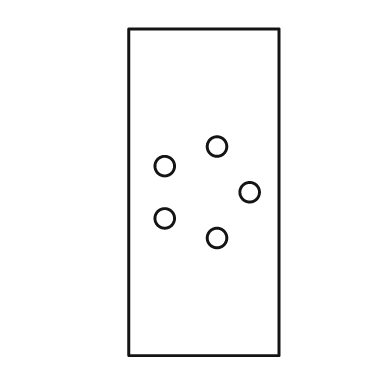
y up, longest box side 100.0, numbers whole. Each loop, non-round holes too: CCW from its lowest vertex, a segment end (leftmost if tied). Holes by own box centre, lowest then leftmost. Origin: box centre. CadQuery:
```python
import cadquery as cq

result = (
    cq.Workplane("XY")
    .moveTo(-23.0, -50.0)
    .lineTo(23.0, -50.0)
    .lineTo(23.0, 50.0)
    .lineTo(-23.0, 50.0)
    .close()
    .moveTo(4.0, -14.0)
    .circle(3.0)
    .moveTo(-12.0, -8.0)
    .circle(3.0)
    .moveTo(14.0, 0.0)
    .circle(3.0)
    .moveTo(-12.0, 8.0)
    .circle(3.0)
    .moveTo(4.0, 14.0)
    .circle(3.0)
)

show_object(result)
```